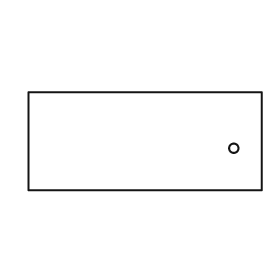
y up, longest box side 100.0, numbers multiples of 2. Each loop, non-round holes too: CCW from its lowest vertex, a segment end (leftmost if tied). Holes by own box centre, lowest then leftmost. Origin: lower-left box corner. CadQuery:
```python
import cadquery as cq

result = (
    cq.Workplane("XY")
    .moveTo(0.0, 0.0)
    .lineTo(100.0, 0.0)
    .lineTo(100.0, 42.0)
    .lineTo(0.0, 42.0)
    .close()
    .moveTo(88.0, 18.0)
    .circle(2.0)
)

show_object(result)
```